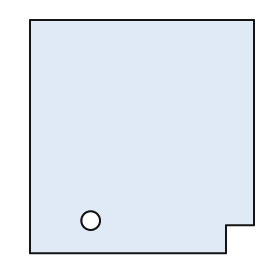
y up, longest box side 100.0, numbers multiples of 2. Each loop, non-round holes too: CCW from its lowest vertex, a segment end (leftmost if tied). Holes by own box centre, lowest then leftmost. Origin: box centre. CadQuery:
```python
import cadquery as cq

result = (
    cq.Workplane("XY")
    .moveTo(-48.0, -50.0)
    .lineTo(36.0, -50.0)
    .lineTo(36.0, -38.0)
    .lineTo(48.0, -38.0)
    .lineTo(48.0, 50.0)
    .lineTo(-48.0, 50.0)
    .close()
    .moveTo(-22.0, -36.0)
    .circle(4.0)
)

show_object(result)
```